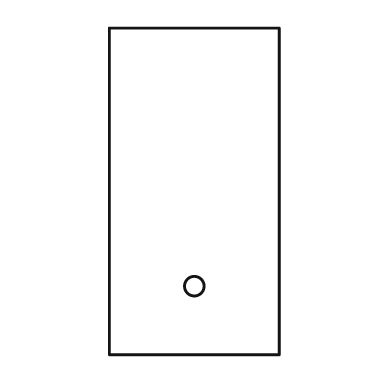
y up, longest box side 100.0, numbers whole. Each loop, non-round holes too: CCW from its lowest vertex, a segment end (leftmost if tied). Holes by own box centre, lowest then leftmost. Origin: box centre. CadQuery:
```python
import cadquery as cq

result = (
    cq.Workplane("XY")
    .moveTo(-26.0, -50.0)
    .lineTo(26.0, -50.0)
    .lineTo(26.0, 50.0)
    .lineTo(-26.0, 50.0)
    .close()
    .moveTo(0.0, -29.0)
    .circle(3.0)
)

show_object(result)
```